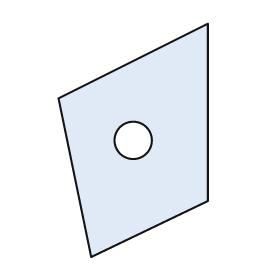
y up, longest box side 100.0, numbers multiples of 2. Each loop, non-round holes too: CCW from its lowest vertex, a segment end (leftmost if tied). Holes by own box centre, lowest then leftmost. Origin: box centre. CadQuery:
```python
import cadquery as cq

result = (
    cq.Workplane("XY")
    .moveTo(-18.0, -50.0)
    .lineTo(32.0, -26.0)
    .lineTo(32.0, 50.0)
    .lineTo(-32.0, 18.0)
    .close()
    .moveTo(0.0, 0.0)
    .circle(8.0)
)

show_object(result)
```